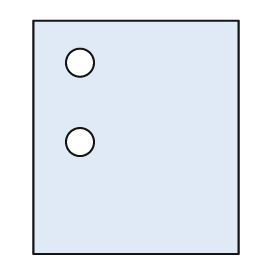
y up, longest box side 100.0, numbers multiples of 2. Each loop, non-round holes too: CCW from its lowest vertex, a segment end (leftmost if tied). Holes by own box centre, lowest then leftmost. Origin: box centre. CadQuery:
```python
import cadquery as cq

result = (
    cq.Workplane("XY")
    .moveTo(-44.0, -50.0)
    .lineTo(44.0, -50.0)
    .lineTo(44.0, 50.0)
    .lineTo(-44.0, 50.0)
    .close()
    .moveTo(-24.0, -2.0)
    .circle(6.0)
    .moveTo(-24.0, 32.0)
    .circle(6.0)
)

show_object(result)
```